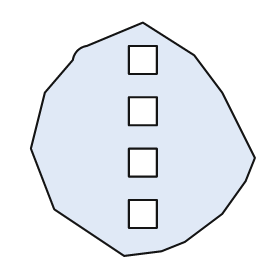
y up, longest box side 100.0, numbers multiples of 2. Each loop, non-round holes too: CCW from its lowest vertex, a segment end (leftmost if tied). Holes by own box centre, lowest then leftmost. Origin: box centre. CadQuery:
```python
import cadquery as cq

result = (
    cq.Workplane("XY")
    .moveTo(-8.0, -50.0)
    .lineTo(8.0, -48.0)
    .lineTo(18.0, -44.0)
    .lineTo(34.0, -32.0)
    .lineTo(44.0, -18.0)
    .lineTo(48.0, -8.0)
    .lineTo(34.0, 20.0)
    .lineTo(22.0, 36.0)
    .lineTo(0.0, 50.0)
    .lineTo(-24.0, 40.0)
    .threePointArc((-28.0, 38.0), (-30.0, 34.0))
    .lineTo(-42.0, 20.0)
    .lineTo(-48.0, -4.0)
    .lineTo(-38.0, -30.0)
    .close()
    .moveTo(-6.0, -38.0)
    .lineTo(6.0, -38.0)
    .lineTo(6.0, -26.0)
    .lineTo(-6.0, -26.0)
    .close()
    .moveTo(-6.0, -16.0)
    .lineTo(6.0, -16.0)
    .lineTo(6.0, -4.0)
    .lineTo(-6.0, -4.0)
    .close()
    .moveTo(-6.0, 6.0)
    .lineTo(6.0, 6.0)
    .lineTo(6.0, 18.0)
    .lineTo(-6.0, 18.0)
    .close()
    .moveTo(-6.0, 28.0)
    .lineTo(6.0, 28.0)
    .lineTo(6.0, 40.0)
    .lineTo(-6.0, 40.0)
    .close()
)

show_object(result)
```